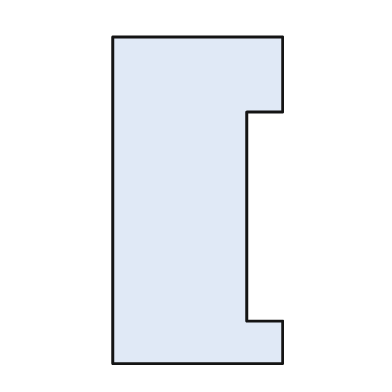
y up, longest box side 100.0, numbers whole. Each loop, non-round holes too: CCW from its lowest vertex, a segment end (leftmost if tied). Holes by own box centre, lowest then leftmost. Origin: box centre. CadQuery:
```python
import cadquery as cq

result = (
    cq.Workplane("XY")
    .moveTo(-26.0, -50.0)
    .lineTo(26.0, -50.0)
    .lineTo(26.0, -37.0)
    .lineTo(15.0, -37.0)
    .lineTo(15.0, 27.0)
    .lineTo(26.0, 27.0)
    .lineTo(26.0, 50.0)
    .lineTo(-26.0, 50.0)
    .close()
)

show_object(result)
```